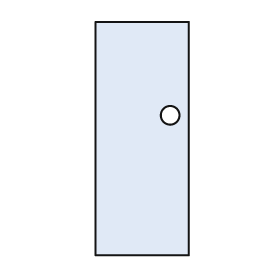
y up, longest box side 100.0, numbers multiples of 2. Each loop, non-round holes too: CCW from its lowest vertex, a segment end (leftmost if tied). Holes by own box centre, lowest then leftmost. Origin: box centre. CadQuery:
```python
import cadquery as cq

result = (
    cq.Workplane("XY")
    .moveTo(-20.0, -50.0)
    .lineTo(20.0, -50.0)
    .lineTo(20.0, 50.0)
    .lineTo(-20.0, 50.0)
    .close()
    .moveTo(12.0, 10.0)
    .circle(4.0)
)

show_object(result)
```